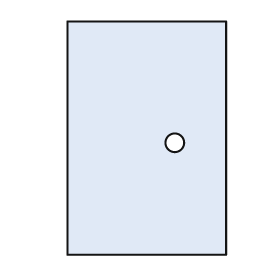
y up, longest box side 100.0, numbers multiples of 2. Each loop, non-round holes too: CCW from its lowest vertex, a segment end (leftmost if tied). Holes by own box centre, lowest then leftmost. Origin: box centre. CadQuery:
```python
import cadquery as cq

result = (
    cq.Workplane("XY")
    .moveTo(-34.0, -50.0)
    .lineTo(34.0, -50.0)
    .lineTo(34.0, 50.0)
    .lineTo(-34.0, 50.0)
    .close()
    .moveTo(12.0, -2.0)
    .circle(4.0)
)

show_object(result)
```